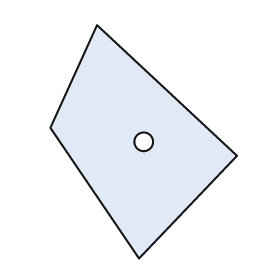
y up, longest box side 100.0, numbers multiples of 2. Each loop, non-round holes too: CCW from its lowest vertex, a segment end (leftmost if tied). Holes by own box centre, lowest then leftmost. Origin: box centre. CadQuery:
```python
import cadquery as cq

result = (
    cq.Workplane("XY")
    .moveTo(-2.0, -50.0)
    .lineTo(40.0, -6.0)
    .lineTo(-20.0, 50.0)
    .lineTo(-40.0, 6.0)
    .close()
    .moveTo(0.0, 0.0)
    .circle(4.0)
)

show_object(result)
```